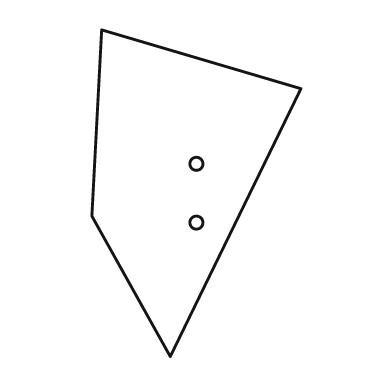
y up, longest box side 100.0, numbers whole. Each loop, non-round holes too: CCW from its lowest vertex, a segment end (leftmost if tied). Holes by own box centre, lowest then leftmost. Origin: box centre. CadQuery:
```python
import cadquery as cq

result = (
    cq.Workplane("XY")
    .moveTo(-8.0, -50.0)
    .lineTo(32.0, 32.0)
    .lineTo(-29.0, 50.0)
    .lineTo(-32.0, -7.0)
    .close()
    .moveTo(0.0, -9.0)
    .circle(2.0)
    .moveTo(0.0, 9.0)
    .circle(2.0)
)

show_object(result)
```